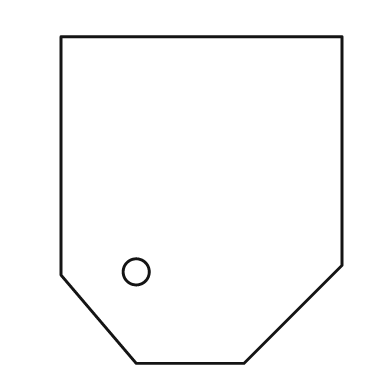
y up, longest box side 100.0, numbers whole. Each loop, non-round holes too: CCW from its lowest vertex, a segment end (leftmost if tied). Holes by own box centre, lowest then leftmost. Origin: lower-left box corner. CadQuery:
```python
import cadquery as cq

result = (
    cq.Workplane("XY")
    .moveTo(23.0, 0.0)
    .lineTo(56.0, 0.0)
    .lineTo(86.0, 30.0)
    .lineTo(86.0, 100.0)
    .lineTo(0.0, 100.0)
    .lineTo(0.0, 27.0)
    .close()
    .moveTo(23.0, 28.0)
    .circle(4.0)
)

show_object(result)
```